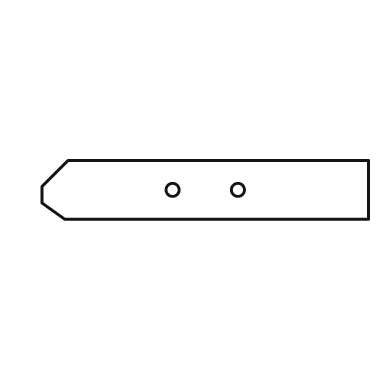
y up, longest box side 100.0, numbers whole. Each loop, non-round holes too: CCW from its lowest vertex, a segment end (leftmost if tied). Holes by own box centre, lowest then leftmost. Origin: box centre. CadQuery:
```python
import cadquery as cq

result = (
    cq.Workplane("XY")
    .moveTo(-43.0, -9.0)
    .lineTo(50.0, -9.0)
    .lineTo(50.0, 9.0)
    .lineTo(-42.0, 9.0)
    .lineTo(-50.0, 1.0)
    .lineTo(-50.0, -4.0)
    .close()
    .moveTo(-10.0, 0.0)
    .circle(2.0)
    .moveTo(10.0, 0.0)
    .circle(2.0)
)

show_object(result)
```